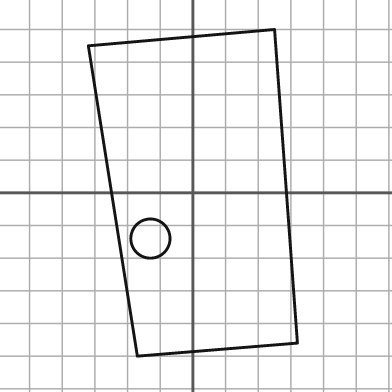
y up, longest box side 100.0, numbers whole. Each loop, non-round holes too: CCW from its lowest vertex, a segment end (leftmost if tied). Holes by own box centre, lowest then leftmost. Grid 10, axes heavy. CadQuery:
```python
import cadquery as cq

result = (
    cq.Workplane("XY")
    .moveTo(-17.0, -50.0)
    .lineTo(32.0, -46.0)
    .lineTo(25.0, 50.0)
    .lineTo(-32.0, 45.0)
    .close()
    .moveTo(-13.0, -14.0)
    .circle(6.0)
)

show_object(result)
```